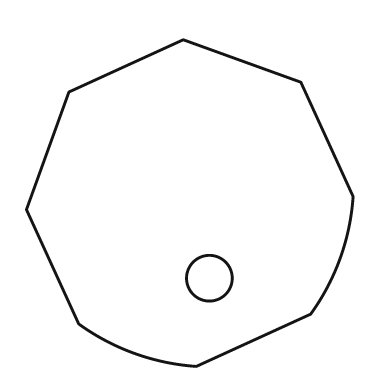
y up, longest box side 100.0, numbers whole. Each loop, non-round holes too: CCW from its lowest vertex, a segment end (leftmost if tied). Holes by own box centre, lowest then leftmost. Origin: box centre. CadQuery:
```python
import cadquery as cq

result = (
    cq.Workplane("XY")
    .moveTo(2.0, -50.0)
    .lineTo(37.0, -34.0)
    .threePointArc((46.0, -17.0), (50.0, 2.0))
    .lineTo(34.0, 37.0)
    .lineTo(-2.0, 50.0)
    .lineTo(-37.0, 34.0)
    .lineTo(-50.0, -2.0)
    .lineTo(-34.0, -37.0)
    .threePointArc((-17.0, -46.0), (2.0, -50.0))
    .close()
    .moveTo(6.0, -23.0)
    .circle(7.0)
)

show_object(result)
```